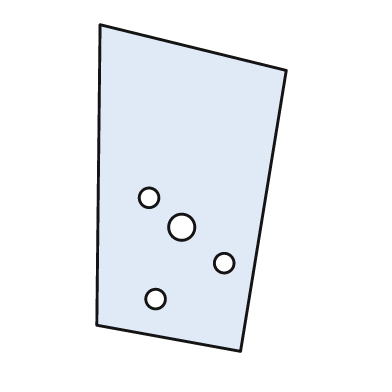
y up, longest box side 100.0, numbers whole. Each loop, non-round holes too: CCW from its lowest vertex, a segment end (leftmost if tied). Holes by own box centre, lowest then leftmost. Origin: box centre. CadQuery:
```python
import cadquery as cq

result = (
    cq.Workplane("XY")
    .moveTo(15.0, -50.0)
    .lineTo(29.0, 36.0)
    .lineTo(-28.0, 50.0)
    .lineTo(-29.0, -42.0)
    .close()
    .moveTo(-11.0, -34.0)
    .circle(3.0)
    .moveTo(10.0, -23.0)
    .circle(3.0)
    .moveTo(-3.0, -12.0)
    .circle(4.0)
    .moveTo(-13.0, -3.0)
    .circle(3.0)
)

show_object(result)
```